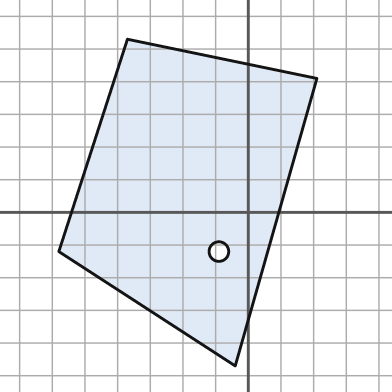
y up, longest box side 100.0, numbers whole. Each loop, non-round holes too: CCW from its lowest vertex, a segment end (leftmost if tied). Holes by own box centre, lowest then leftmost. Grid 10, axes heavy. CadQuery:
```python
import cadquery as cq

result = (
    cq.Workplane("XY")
    .moveTo(-4.0, -47.0)
    .lineTo(21.0, 41.0)
    .lineTo(-37.0, 53.0)
    .lineTo(-58.0, -12.0)
    .close()
    .moveTo(-9.0, -12.0)
    .circle(3.0)
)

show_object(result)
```